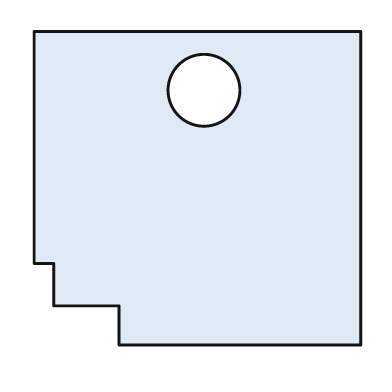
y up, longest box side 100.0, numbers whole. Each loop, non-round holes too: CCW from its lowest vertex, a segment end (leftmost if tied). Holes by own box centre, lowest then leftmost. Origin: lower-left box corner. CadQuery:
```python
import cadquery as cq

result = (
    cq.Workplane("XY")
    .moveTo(26.0, 0.0)
    .lineTo(100.0, 0.0)
    .lineTo(100.0, 96.0)
    .lineTo(0.0, 96.0)
    .lineTo(0.0, 25.0)
    .lineTo(6.0, 25.0)
    .lineTo(6.0, 12.0)
    .lineTo(26.0, 12.0)
    .close()
    .moveTo(52.0, 78.0)
    .circle(11.0)
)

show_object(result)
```